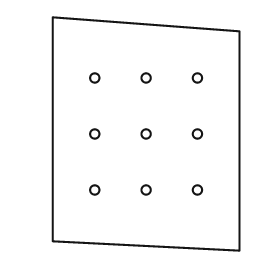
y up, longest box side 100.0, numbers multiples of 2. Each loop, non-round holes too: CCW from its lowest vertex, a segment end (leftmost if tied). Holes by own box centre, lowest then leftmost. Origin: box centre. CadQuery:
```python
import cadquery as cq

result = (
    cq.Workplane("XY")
    .moveTo(40.0, -50.0)
    .lineTo(40.0, 44.0)
    .lineTo(-40.0, 50.0)
    .lineTo(-40.0, -46.0)
    .close()
    .moveTo(-22.0, -24.0)
    .circle(2.0)
    .moveTo(0.0, -24.0)
    .circle(2.0)
    .moveTo(22.0, -24.0)
    .circle(2.0)
    .moveTo(-22.0, 0.0)
    .circle(2.0)
    .moveTo(0.0, 0.0)
    .circle(2.0)
    .moveTo(22.0, 0.0)
    .circle(2.0)
    .moveTo(-22.0, 24.0)
    .circle(2.0)
    .moveTo(0.0, 24.0)
    .circle(2.0)
    .moveTo(22.0, 24.0)
    .circle(2.0)
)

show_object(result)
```